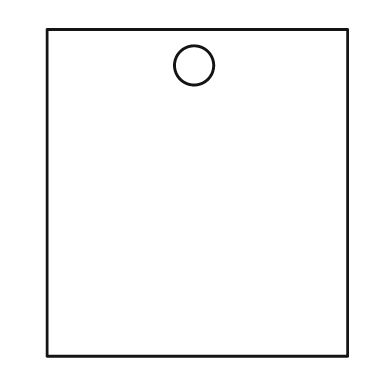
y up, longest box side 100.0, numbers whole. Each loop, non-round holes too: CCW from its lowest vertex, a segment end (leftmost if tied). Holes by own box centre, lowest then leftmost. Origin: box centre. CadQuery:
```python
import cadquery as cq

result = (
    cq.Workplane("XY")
    .moveTo(-46.0, -50.0)
    .lineTo(46.0, -50.0)
    .lineTo(46.0, 50.0)
    .lineTo(-46.0, 50.0)
    .close()
    .moveTo(-1.0, 39.0)
    .circle(6.0)
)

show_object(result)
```